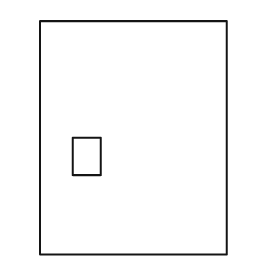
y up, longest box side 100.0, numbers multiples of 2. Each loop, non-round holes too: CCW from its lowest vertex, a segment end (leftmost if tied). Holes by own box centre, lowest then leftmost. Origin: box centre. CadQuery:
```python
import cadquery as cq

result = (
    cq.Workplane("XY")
    .moveTo(-40.0, -50.0)
    .lineTo(40.0, -50.0)
    .lineTo(40.0, 50.0)
    .lineTo(-40.0, 50.0)
    .close()
    .moveTo(-26.0, -16.0)
    .lineTo(-14.0, -16.0)
    .lineTo(-14.0, 0.0)
    .lineTo(-26.0, 0.0)
    .close()
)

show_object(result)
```